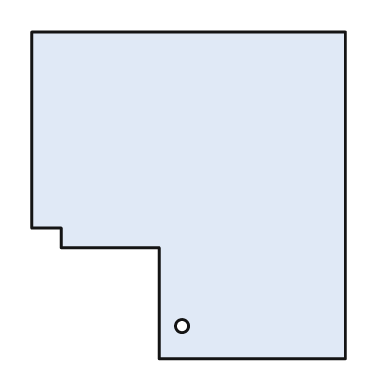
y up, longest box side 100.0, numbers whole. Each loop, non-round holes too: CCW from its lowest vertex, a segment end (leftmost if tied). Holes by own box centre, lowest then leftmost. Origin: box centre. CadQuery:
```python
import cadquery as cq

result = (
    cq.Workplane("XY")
    .moveTo(-9.0, -50.0)
    .lineTo(48.0, -50.0)
    .lineTo(48.0, 50.0)
    .lineTo(-48.0, 50.0)
    .lineTo(-48.0, -10.0)
    .lineTo(-39.0, -10.0)
    .lineTo(-39.0, -16.0)
    .lineTo(-9.0, -16.0)
    .close()
    .moveTo(-2.0, -40.0)
    .circle(2.0)
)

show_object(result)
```